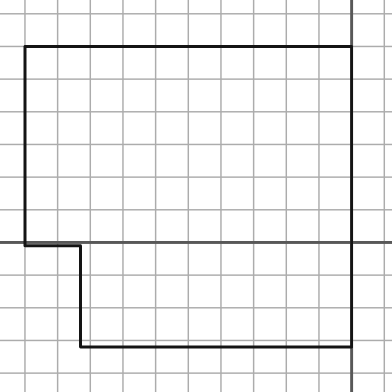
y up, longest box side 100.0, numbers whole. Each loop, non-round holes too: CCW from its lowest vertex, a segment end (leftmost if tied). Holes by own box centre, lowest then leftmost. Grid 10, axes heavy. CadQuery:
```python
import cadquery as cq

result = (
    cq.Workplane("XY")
    .moveTo(-83.0, -32.0)
    .lineTo(0.0, -32.0)
    .lineTo(0.0, 60.0)
    .lineTo(-100.0, 60.0)
    .lineTo(-100.0, -1.0)
    .lineTo(-83.0, -1.0)
    .close()
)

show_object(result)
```